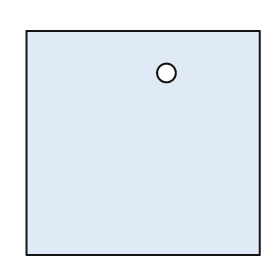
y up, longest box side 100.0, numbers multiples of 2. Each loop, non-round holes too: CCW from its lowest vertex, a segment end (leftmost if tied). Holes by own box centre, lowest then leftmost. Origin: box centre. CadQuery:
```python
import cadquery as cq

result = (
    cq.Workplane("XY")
    .moveTo(-50.0, -48.0)
    .lineTo(50.0, -48.0)
    .lineTo(50.0, 48.0)
    .lineTo(-50.0, 48.0)
    .close()
    .moveTo(10.0, 30.0)
    .circle(4.0)
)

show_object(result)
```